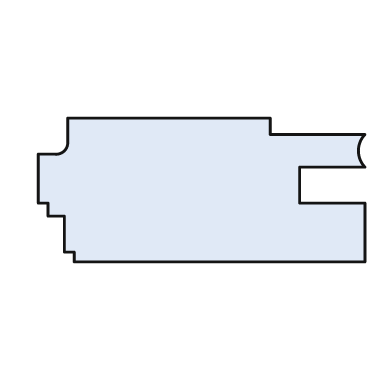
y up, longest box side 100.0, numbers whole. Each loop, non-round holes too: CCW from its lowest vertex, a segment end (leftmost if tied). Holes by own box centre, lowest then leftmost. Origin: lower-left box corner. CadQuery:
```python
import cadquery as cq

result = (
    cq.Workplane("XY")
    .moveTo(11.0, 0.0)
    .lineTo(100.0, 0.0)
    .lineTo(100.0, 18.0)
    .lineTo(80.0, 18.0)
    .lineTo(80.0, 29.0)
    .lineTo(100.0, 29.0)
    .threePointArc((98.0, 34.0), (100.0, 39.0))
    .lineTo(71.0, 39.0)
    .lineTo(71.0, 44.0)
    .lineTo(9.0, 44.0)
    .lineTo(9.0, 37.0)
    .threePointArc((8.0, 34.0), (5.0, 33.0))
    .lineTo(0.0, 33.0)
    .lineTo(0.0, 18.0)
    .lineTo(3.0, 18.0)
    .lineTo(3.0, 14.0)
    .lineTo(8.0, 14.0)
    .lineTo(8.0, 3.0)
    .lineTo(11.0, 3.0)
    .close()
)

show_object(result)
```